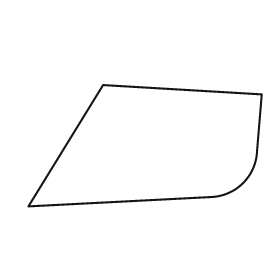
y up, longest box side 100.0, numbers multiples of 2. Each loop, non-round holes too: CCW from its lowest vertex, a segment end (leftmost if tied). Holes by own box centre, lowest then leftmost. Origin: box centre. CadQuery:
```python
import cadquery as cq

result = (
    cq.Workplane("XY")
    .moveTo(-50.0, -26.0)
    .lineTo(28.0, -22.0)
    .threePointArc((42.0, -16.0), (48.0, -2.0))
    .lineTo(50.0, 22.0)
    .lineTo(-18.0, 26.0)
    .close()
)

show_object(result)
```